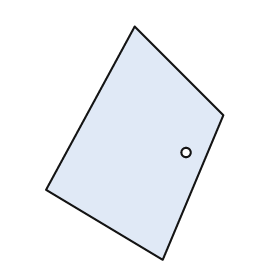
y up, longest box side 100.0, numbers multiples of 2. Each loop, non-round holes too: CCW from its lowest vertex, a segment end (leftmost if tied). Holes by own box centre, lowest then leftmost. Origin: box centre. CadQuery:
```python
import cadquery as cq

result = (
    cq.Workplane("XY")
    .moveTo(12.0, -50.0)
    .lineTo(38.0, 12.0)
    .lineTo(0.0, 50.0)
    .lineTo(-38.0, -20.0)
    .close()
    .moveTo(22.0, -4.0)
    .circle(2.0)
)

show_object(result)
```